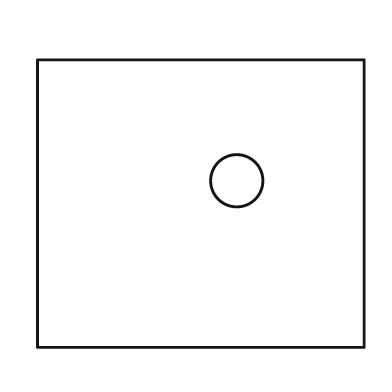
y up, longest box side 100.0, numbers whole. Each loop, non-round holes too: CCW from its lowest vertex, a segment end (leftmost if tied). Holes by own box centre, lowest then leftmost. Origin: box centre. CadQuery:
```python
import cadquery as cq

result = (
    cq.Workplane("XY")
    .moveTo(-50.0, -44.0)
    .lineTo(50.0, -44.0)
    .lineTo(50.0, 44.0)
    .lineTo(-50.0, 44.0)
    .close()
    .moveTo(11.0, 7.0)
    .circle(8.0)
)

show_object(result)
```